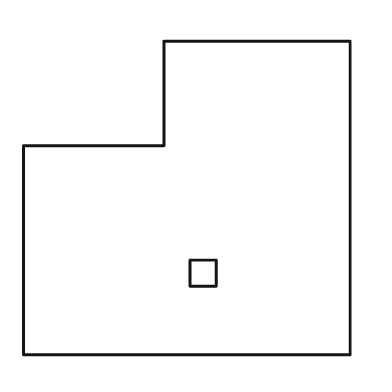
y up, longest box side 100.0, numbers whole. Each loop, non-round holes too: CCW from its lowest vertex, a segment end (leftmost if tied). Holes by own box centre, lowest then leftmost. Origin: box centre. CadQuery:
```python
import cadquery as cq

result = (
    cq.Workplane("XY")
    .moveTo(-50.0, -48.0)
    .lineTo(50.0, -48.0)
    .lineTo(50.0, 48.0)
    .lineTo(-7.0, 48.0)
    .lineTo(-7.0, 16.0)
    .lineTo(-50.0, 16.0)
    .close()
    .moveTo(1.0, -27.0)
    .lineTo(9.0, -27.0)
    .lineTo(9.0, -19.0)
    .lineTo(1.0, -19.0)
    .close()
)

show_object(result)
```